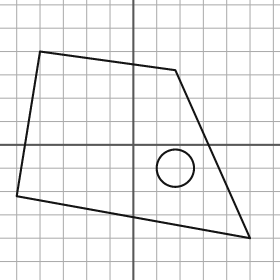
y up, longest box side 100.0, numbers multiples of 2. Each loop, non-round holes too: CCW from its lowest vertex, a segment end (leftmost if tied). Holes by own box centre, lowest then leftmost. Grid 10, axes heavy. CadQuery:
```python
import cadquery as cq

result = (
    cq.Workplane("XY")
    .moveTo(50.0, -40.0)
    .lineTo(18.0, 32.0)
    .lineTo(-40.0, 40.0)
    .lineTo(-50.0, -22.0)
    .close()
    .moveTo(18.0, -10.0)
    .circle(8.0)
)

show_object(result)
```